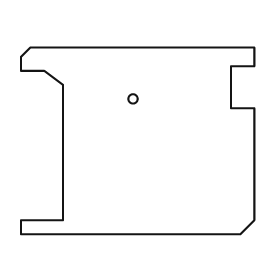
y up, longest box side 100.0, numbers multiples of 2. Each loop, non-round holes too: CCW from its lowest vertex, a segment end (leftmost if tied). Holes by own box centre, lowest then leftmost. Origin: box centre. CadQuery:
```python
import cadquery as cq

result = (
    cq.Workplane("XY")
    .moveTo(-50.0, -40.0)
    .lineTo(44.0, -40.0)
    .lineTo(50.0, -34.0)
    .lineTo(50.0, 14.0)
    .lineTo(40.0, 14.0)
    .lineTo(40.0, 32.0)
    .lineTo(50.0, 32.0)
    .lineTo(50.0, 40.0)
    .lineTo(-46.0, 40.0)
    .lineTo(-50.0, 36.0)
    .lineTo(-50.0, 30.0)
    .lineTo(-40.0, 30.0)
    .lineTo(-32.0, 24.0)
    .lineTo(-32.0, -34.0)
    .lineTo(-50.0, -34.0)
    .close()
    .moveTo(-2.0, 18.0)
    .circle(2.0)
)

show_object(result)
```